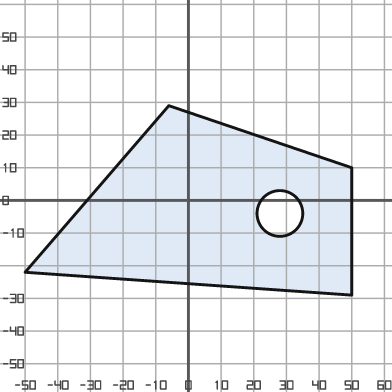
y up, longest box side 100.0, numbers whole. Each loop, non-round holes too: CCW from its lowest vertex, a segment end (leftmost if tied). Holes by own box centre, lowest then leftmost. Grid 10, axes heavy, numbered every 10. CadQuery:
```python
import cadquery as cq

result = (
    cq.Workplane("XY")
    .moveTo(50.0, -29.0)
    .lineTo(50.0, 10.0)
    .lineTo(-6.0, 29.0)
    .lineTo(-50.0, -22.0)
    .close()
    .moveTo(28.0, -4.0)
    .circle(7.0)
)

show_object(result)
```